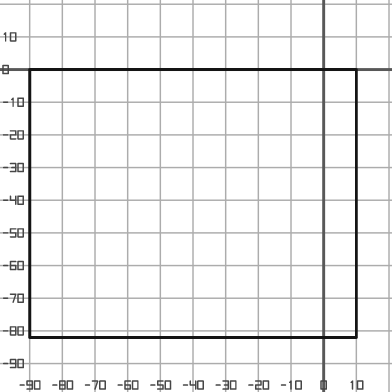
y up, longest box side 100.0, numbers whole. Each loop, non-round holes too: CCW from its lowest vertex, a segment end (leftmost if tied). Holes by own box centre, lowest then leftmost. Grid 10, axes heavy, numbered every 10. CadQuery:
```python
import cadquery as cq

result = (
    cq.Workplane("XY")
    .moveTo(-90.0, -82.0)
    .lineTo(10.0, -82.0)
    .lineTo(10.0, 0.0)
    .lineTo(-90.0, 0.0)
    .close()
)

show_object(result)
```